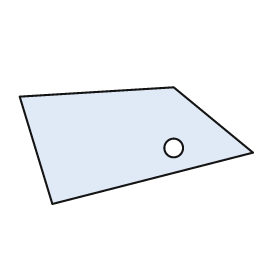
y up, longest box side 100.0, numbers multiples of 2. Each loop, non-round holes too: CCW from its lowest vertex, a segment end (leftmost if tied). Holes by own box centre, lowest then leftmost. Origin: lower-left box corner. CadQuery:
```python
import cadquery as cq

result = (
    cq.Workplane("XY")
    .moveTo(14.0, 0.0)
    .lineTo(100.0, 22.0)
    .lineTo(66.0, 50.0)
    .lineTo(0.0, 46.0)
    .close()
    .moveTo(66.0, 24.0)
    .circle(4.0)
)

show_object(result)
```